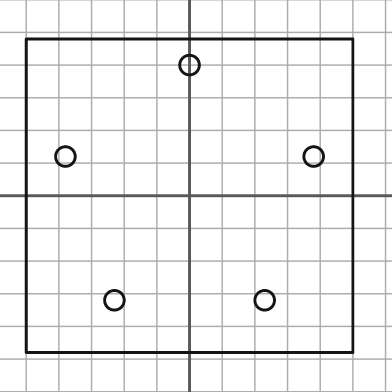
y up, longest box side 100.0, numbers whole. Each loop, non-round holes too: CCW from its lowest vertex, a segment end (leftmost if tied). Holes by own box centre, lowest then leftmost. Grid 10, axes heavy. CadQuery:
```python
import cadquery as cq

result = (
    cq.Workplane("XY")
    .moveTo(-50.0, -48.0)
    .lineTo(50.0, -48.0)
    .lineTo(50.0, 48.0)
    .lineTo(-50.0, 48.0)
    .close()
    .moveTo(-23.0, -32.0)
    .circle(3.0)
    .moveTo(23.0, -32.0)
    .circle(3.0)
    .moveTo(-38.0, 12.0)
    .circle(3.0)
    .moveTo(38.0, 12.0)
    .circle(3.0)
    .moveTo(0.0, 40.0)
    .circle(3.0)
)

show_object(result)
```